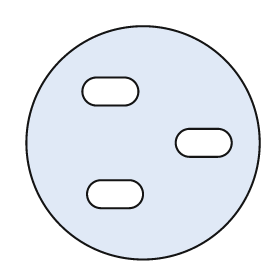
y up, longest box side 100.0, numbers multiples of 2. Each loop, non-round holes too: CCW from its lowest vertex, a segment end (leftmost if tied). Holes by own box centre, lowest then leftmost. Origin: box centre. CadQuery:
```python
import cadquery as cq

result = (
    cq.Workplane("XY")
    .moveTo(0.0, 0.0)
    .circle(50.0)
    .moveTo(-18.0, -28.0)
    .lineTo(-6.0, -28.0)
    .threePointArc((0.0, -22.0), (-6.0, -16.0))
    .lineTo(-18.0, -16.0)
    .threePointArc((-24.0, -22.0), (-18.0, -28.0))
    .close()
    .moveTo(20.0, -6.0)
    .lineTo(32.0, -6.0)
    .threePointArc((38.0, 0.0), (32.0, 6.0))
    .lineTo(20.0, 6.0)
    .threePointArc((14.0, 0.0), (20.0, -6.0))
    .close()
    .moveTo(-20.0, 16.0)
    .lineTo(-8.0, 16.0)
    .threePointArc((-2.0, 22.0), (-8.0, 28.0))
    .lineTo(-20.0, 28.0)
    .threePointArc((-26.0, 22.0), (-20.0, 16.0))
    .close()
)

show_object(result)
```